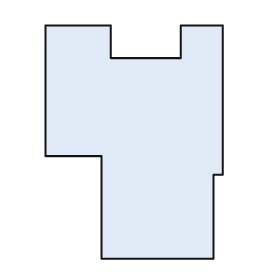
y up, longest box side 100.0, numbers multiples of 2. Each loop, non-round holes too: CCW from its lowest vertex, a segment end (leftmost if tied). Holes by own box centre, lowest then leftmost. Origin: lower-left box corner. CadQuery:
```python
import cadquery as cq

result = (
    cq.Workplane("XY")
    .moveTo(24.0, 0.0)
    .lineTo(72.0, 0.0)
    .lineTo(72.0, 36.0)
    .lineTo(76.0, 36.0)
    .lineTo(76.0, 100.0)
    .lineTo(58.0, 100.0)
    .lineTo(58.0, 86.0)
    .lineTo(28.0, 86.0)
    .lineTo(28.0, 100.0)
    .lineTo(0.0, 100.0)
    .lineTo(0.0, 44.0)
    .lineTo(24.0, 44.0)
    .close()
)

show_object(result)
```